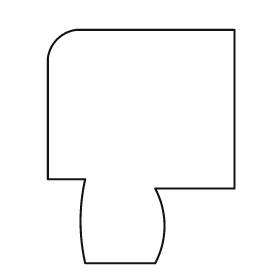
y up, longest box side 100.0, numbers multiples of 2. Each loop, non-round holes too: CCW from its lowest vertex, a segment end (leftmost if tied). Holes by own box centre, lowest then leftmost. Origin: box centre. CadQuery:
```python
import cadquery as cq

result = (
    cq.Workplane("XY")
    .moveTo(-24.0, -50.0)
    .lineTo(6.0, -50.0)
    .threePointArc((10.0, -34.0), (6.0, -18.0))
    .lineTo(40.0, -18.0)
    .lineTo(40.0, 50.0)
    .lineTo(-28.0, 50.0)
    .threePointArc((-36.0, 46.0), (-40.0, 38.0))
    .lineTo(-40.0, -14.0)
    .lineTo(-24.0, -14.0)
    .threePointArc((-26.0, -32.0), (-24.0, -50.0))
    .close()
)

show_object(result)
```